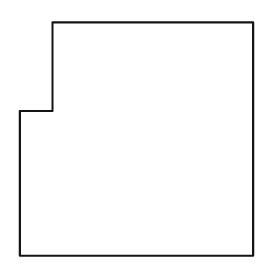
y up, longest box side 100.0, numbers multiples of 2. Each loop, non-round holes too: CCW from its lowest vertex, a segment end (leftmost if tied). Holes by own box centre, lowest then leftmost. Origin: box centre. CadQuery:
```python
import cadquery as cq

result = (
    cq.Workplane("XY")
    .moveTo(-50.0, -50.0)
    .lineTo(50.0, -50.0)
    .lineTo(50.0, 50.0)
    .lineTo(-36.0, 50.0)
    .lineTo(-36.0, 12.0)
    .lineTo(-50.0, 12.0)
    .close()
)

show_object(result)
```